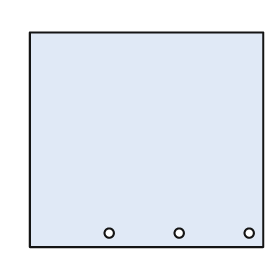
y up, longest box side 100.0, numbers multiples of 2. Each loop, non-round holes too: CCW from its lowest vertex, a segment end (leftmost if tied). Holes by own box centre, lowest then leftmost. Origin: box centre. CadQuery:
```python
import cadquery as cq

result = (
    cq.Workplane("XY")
    .moveTo(-50.0, -46.0)
    .lineTo(50.0, -46.0)
    .lineTo(50.0, 46.0)
    .lineTo(-50.0, 46.0)
    .close()
    .moveTo(-16.0, -40.0)
    .circle(2.0)
    .moveTo(14.0, -40.0)
    .circle(2.0)
    .moveTo(44.0, -40.0)
    .circle(2.0)
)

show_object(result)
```